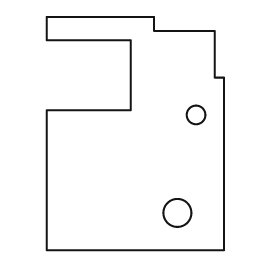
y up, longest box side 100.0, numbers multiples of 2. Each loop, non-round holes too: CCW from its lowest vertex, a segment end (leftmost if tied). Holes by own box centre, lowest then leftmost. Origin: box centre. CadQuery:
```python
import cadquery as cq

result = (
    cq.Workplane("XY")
    .moveTo(-38.0, -50.0)
    .lineTo(38.0, -50.0)
    .lineTo(38.0, 24.0)
    .lineTo(34.0, 24.0)
    .lineTo(34.0, 44.0)
    .lineTo(8.0, 44.0)
    .lineTo(8.0, 50.0)
    .lineTo(-38.0, 50.0)
    .lineTo(-38.0, 40.0)
    .lineTo(-2.0, 40.0)
    .lineTo(-2.0, 10.0)
    .lineTo(-38.0, 10.0)
    .close()
    .moveTo(18.0, -34.0)
    .circle(6.0)
    .moveTo(26.0, 8.0)
    .circle(4.0)
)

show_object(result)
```